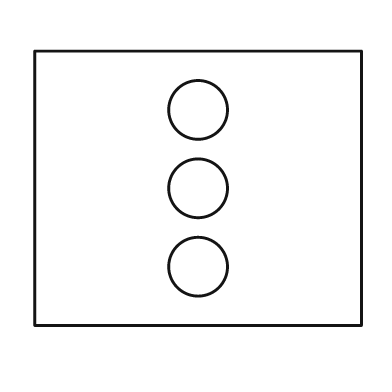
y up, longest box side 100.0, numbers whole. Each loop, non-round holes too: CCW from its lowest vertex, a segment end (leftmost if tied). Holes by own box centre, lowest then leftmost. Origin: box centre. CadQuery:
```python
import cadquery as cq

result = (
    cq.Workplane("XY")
    .moveTo(-50.0, -42.0)
    .lineTo(50.0, -42.0)
    .lineTo(50.0, 42.0)
    .lineTo(-50.0, 42.0)
    .close()
    .moveTo(0.0, -24.0)
    .circle(9.0)
    .moveTo(0.0, 0.0)
    .circle(9.0)
    .moveTo(0.0, 24.0)
    .circle(9.0)
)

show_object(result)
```